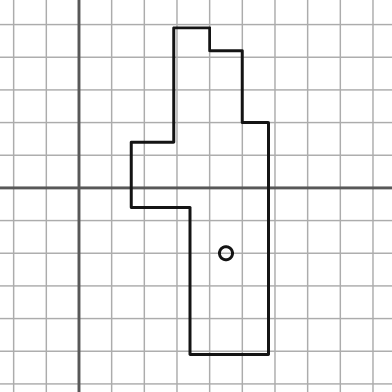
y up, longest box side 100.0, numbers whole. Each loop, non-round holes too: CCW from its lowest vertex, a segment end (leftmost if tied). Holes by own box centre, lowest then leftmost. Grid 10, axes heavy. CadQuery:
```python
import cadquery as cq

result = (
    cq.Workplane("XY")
    .moveTo(34.0, -51.0)
    .lineTo(58.0, -51.0)
    .lineTo(58.0, 20.0)
    .lineTo(50.0, 20.0)
    .lineTo(50.0, 42.0)
    .lineTo(40.0, 42.0)
    .lineTo(40.0, 49.0)
    .lineTo(29.0, 49.0)
    .lineTo(29.0, 14.0)
    .lineTo(16.0, 14.0)
    .lineTo(16.0, -6.0)
    .lineTo(34.0, -6.0)
    .close()
    .moveTo(45.0, -20.0)
    .circle(2.0)
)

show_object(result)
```